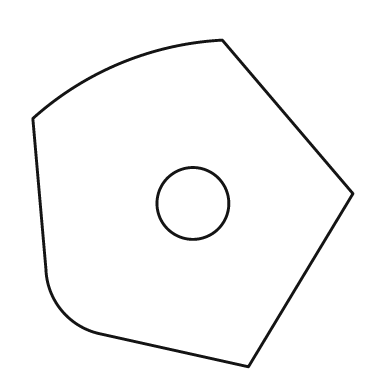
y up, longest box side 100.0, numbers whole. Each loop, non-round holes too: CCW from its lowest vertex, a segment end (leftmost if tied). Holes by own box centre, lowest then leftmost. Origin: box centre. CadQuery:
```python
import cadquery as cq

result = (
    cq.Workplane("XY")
    .moveTo(17.0, -50.0)
    .lineTo(49.0, 3.0)
    .lineTo(9.0, 50.0)
    .threePointArc((-22.0, 43.0), (-49.0, 26.0))
    .lineTo(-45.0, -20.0)
    .threePointArc((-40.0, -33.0), (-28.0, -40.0))
    .close()
    .moveTo(0.0, 0.0)
    .circle(11.0)
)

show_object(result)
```